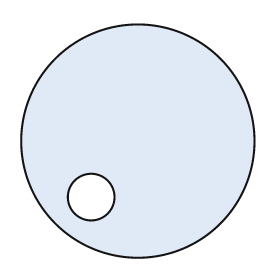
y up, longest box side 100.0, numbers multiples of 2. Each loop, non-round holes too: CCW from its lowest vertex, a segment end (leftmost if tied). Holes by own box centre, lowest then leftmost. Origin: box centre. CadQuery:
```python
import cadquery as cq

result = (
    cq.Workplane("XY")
    .moveTo(0.0, 0.0)
    .circle(50.0)
    .moveTo(-20.0, -24.0)
    .circle(10.0)
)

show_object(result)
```